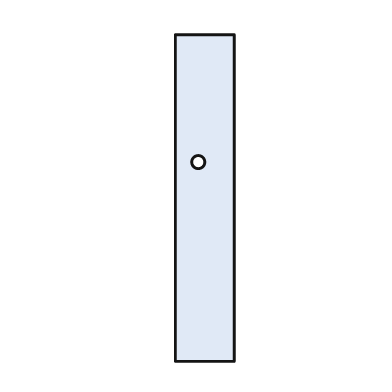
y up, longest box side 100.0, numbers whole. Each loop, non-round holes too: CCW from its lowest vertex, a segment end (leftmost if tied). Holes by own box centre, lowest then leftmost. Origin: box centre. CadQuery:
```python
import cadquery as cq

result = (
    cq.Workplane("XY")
    .moveTo(-9.0, -50.0)
    .lineTo(9.0, -50.0)
    .lineTo(9.0, 50.0)
    .lineTo(-9.0, 50.0)
    .close()
    .moveTo(-2.0, 11.0)
    .circle(2.0)
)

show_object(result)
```